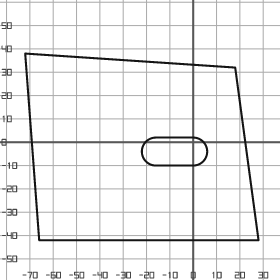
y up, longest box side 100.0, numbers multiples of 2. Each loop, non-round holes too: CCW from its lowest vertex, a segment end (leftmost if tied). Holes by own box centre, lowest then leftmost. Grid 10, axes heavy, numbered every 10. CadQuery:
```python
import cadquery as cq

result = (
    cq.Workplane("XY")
    .moveTo(-66.0, -42.0)
    .lineTo(28.0, -42.0)
    .lineTo(18.0, 32.0)
    .lineTo(-72.0, 38.0)
    .close()
    .moveTo(-16.0, -10.0)
    .lineTo(0.0, -10.0)
    .threePointArc((6.0, -4.0), (0.0, 2.0))
    .lineTo(-16.0, 2.0)
    .threePointArc((-22.0, -4.0), (-16.0, -10.0))
    .close()
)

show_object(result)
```